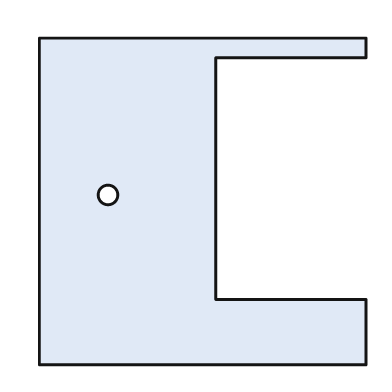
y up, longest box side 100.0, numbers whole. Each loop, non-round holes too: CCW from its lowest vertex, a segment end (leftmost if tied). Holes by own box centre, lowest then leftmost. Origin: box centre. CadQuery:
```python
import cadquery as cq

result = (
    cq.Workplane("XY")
    .moveTo(-50.0, -50.0)
    .lineTo(50.0, -50.0)
    .lineTo(50.0, -30.0)
    .lineTo(4.0, -30.0)
    .lineTo(4.0, 44.0)
    .lineTo(50.0, 44.0)
    .lineTo(50.0, 50.0)
    .lineTo(-50.0, 50.0)
    .close()
    .moveTo(-29.0, 2.0)
    .circle(3.0)
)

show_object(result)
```